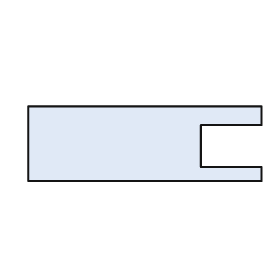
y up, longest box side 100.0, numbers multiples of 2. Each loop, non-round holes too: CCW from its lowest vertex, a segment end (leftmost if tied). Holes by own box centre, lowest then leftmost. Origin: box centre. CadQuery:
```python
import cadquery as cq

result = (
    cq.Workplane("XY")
    .moveTo(-50.0, -16.0)
    .lineTo(50.0, -16.0)
    .lineTo(50.0, -10.0)
    .lineTo(24.0, -10.0)
    .lineTo(24.0, 8.0)
    .lineTo(50.0, 8.0)
    .lineTo(50.0, 16.0)
    .lineTo(-50.0, 16.0)
    .close()
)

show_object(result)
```